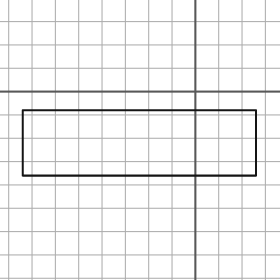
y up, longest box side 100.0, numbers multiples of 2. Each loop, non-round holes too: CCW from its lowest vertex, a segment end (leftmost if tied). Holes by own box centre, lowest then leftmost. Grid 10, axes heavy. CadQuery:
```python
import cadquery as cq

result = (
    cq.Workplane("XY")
    .moveTo(-74.0, -36.0)
    .lineTo(26.0, -36.0)
    .lineTo(26.0, -8.0)
    .lineTo(-74.0, -8.0)
    .close()
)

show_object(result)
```